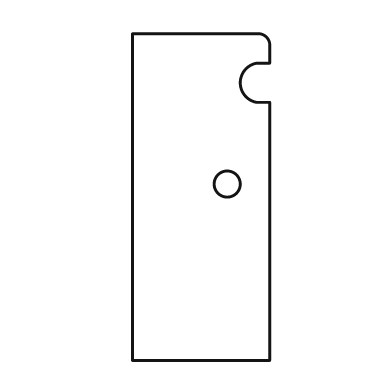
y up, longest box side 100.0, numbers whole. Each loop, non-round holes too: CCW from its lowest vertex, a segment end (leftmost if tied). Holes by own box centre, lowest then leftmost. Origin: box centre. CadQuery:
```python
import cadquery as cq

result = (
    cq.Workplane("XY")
    .moveTo(-21.0, -50.0)
    .lineTo(21.0, -50.0)
    .lineTo(21.0, 29.0)
    .lineTo(17.0, 29.0)
    .threePointArc((12.0, 35.0), (17.0, 41.0))
    .lineTo(21.0, 41.0)
    .lineTo(21.0, 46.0)
    .threePointArc((20.0, 49.0), (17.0, 50.0))
    .lineTo(-21.0, 50.0)
    .close()
    .moveTo(8.0, 4.0)
    .circle(4.0)
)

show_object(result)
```